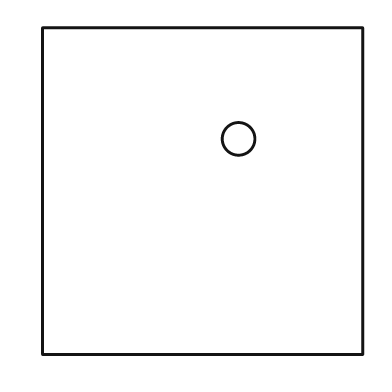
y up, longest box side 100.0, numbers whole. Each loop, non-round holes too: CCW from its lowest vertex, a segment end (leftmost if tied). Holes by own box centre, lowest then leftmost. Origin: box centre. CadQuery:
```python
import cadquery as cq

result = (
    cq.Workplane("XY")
    .moveTo(-49.0, -50.0)
    .lineTo(49.0, -50.0)
    .lineTo(49.0, 50.0)
    .lineTo(-49.0, 50.0)
    .close()
    .moveTo(11.0, 16.0)
    .circle(5.0)
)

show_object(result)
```